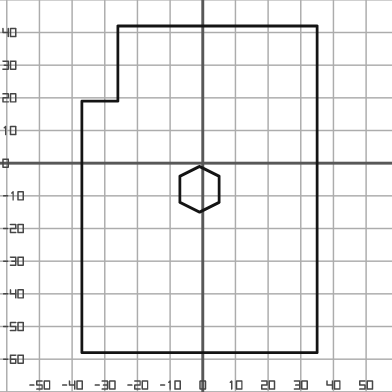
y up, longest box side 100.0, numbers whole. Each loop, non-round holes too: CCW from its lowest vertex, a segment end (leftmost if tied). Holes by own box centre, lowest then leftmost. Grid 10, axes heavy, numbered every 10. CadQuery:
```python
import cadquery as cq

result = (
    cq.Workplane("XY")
    .moveTo(-37.0, -58.0)
    .lineTo(35.0, -58.0)
    .lineTo(35.0, 42.0)
    .lineTo(-26.0, 42.0)
    .lineTo(-26.0, 19.0)
    .lineTo(-37.0, 19.0)
    .close()
    .moveTo(-1.0, -15.0)
    .lineTo(5.0, -12.0)
    .lineTo(5.0, -4.0)
    .lineTo(-1.0, -1.0)
    .lineTo(-7.0, -4.0)
    .lineTo(-7.0, -12.0)
    .close()
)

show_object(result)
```